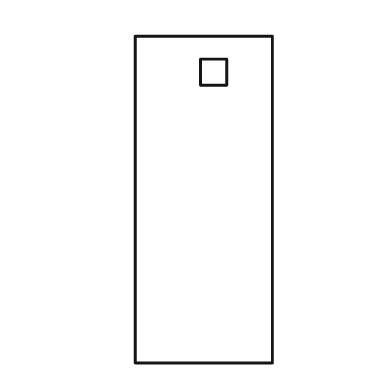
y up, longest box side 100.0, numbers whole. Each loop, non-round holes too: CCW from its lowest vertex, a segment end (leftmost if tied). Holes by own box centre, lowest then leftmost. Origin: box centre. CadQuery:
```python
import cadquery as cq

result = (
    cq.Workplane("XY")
    .moveTo(-21.0, -50.0)
    .lineTo(21.0, -50.0)
    .lineTo(21.0, 50.0)
    .lineTo(-21.0, 50.0)
    .close()
    .moveTo(-1.0, 35.0)
    .lineTo(7.0, 35.0)
    .lineTo(7.0, 43.0)
    .lineTo(-1.0, 43.0)
    .close()
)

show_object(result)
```